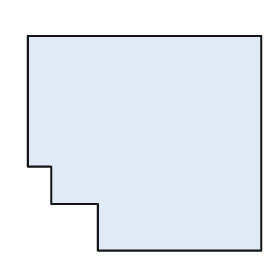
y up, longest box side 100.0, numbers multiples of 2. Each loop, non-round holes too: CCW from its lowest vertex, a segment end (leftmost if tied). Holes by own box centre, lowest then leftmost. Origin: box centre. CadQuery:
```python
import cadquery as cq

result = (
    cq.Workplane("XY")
    .moveTo(-20.0, -46.0)
    .lineTo(50.0, -46.0)
    .lineTo(50.0, 46.0)
    .lineTo(-50.0, 46.0)
    .lineTo(-50.0, -10.0)
    .lineTo(-40.0, -10.0)
    .lineTo(-40.0, -26.0)
    .lineTo(-20.0, -26.0)
    .close()
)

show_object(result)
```